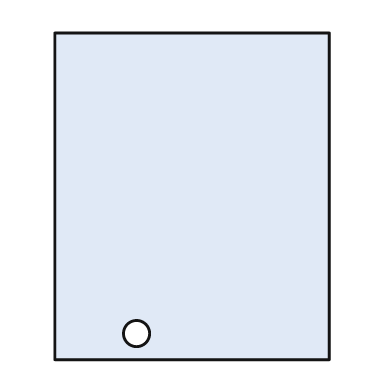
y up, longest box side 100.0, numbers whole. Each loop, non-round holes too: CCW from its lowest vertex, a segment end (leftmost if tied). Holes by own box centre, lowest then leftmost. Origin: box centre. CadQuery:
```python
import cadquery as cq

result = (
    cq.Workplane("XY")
    .moveTo(-42.0, -50.0)
    .lineTo(42.0, -50.0)
    .lineTo(42.0, 50.0)
    .lineTo(-42.0, 50.0)
    .close()
    .moveTo(-17.0, -42.0)
    .circle(4.0)
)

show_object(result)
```